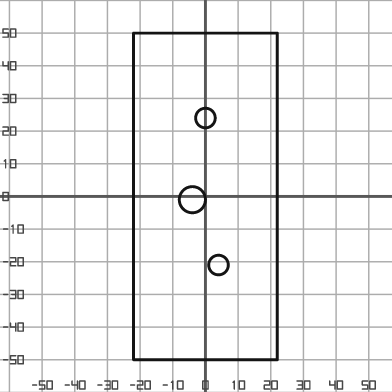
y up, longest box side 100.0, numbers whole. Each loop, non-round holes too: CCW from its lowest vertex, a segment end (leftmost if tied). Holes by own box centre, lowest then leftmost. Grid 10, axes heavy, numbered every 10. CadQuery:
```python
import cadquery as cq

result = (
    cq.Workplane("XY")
    .moveTo(-22.0, -50.0)
    .lineTo(22.0, -50.0)
    .lineTo(22.0, 50.0)
    .lineTo(-22.0, 50.0)
    .close()
    .moveTo(4.0, -21.0)
    .circle(3.0)
    .moveTo(-4.0, -1.0)
    .circle(4.0)
    .moveTo(0.0, 24.0)
    .circle(3.0)
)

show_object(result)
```